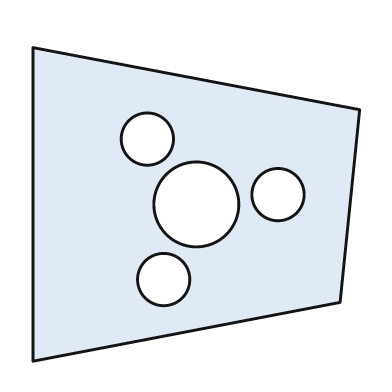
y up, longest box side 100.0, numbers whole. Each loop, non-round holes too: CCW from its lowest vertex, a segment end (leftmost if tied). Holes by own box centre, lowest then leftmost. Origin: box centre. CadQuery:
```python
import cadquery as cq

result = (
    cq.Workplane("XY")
    .moveTo(-50.0, -48.0)
    .lineTo(44.0, -30.0)
    .lineTo(50.0, 29.0)
    .lineTo(-50.0, 48.0)
    .close()
    .moveTo(-10.0, -23.0)
    .circle(8.0)
    .moveTo(0.0, 0.0)
    .circle(13.0)
    .moveTo(25.0, 3.0)
    .circle(8.0)
    .moveTo(-15.0, 20.0)
    .circle(8.0)
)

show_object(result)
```